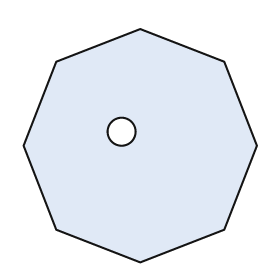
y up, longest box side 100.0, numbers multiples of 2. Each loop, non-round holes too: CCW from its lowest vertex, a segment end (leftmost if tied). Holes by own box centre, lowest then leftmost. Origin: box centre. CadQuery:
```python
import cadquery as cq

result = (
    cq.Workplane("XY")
    .moveTo(0.0, -50.0)
    .lineTo(36.0, -36.0)
    .lineTo(50.0, 0.0)
    .lineTo(36.0, 36.0)
    .lineTo(0.0, 50.0)
    .lineTo(-36.0, 36.0)
    .lineTo(-50.0, 0.0)
    .lineTo(-36.0, -36.0)
    .close()
    .moveTo(-8.0, 6.0)
    .circle(6.0)
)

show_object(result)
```